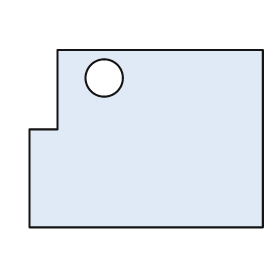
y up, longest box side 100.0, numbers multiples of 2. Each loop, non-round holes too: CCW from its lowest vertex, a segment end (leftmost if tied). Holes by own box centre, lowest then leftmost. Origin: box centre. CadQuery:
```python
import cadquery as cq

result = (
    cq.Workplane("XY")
    .moveTo(-50.0, -38.0)
    .lineTo(50.0, -38.0)
    .lineTo(50.0, 38.0)
    .lineTo(-38.0, 38.0)
    .lineTo(-38.0, 4.0)
    .lineTo(-50.0, 4.0)
    .close()
    .moveTo(-18.0, 26.0)
    .circle(8.0)
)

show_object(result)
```